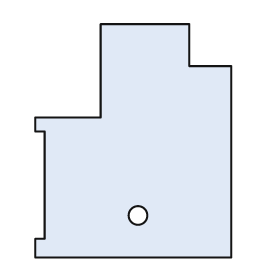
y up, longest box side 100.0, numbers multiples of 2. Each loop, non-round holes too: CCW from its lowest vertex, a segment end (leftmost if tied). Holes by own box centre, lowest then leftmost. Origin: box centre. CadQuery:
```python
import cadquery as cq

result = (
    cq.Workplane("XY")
    .moveTo(-42.0, -50.0)
    .lineTo(42.0, -50.0)
    .lineTo(42.0, 32.0)
    .lineTo(24.0, 32.0)
    .lineTo(24.0, 50.0)
    .lineTo(-14.0, 50.0)
    .lineTo(-14.0, 10.0)
    .lineTo(-42.0, 10.0)
    .lineTo(-42.0, 4.0)
    .lineTo(-38.0, 4.0)
    .lineTo(-38.0, -42.0)
    .lineTo(-42.0, -42.0)
    .close()
    .moveTo(2.0, -32.0)
    .circle(4.0)
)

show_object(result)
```